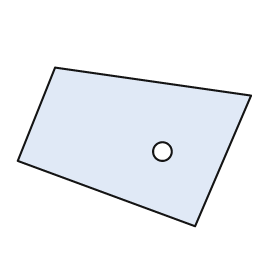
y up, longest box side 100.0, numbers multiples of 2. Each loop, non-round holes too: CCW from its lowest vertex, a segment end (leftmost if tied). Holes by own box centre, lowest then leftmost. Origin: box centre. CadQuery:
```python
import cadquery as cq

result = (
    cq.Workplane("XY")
    .moveTo(26.0, -34.0)
    .lineTo(50.0, 22.0)
    .lineTo(-34.0, 34.0)
    .lineTo(-50.0, -6.0)
    .close()
    .moveTo(12.0, -2.0)
    .circle(4.0)
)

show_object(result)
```